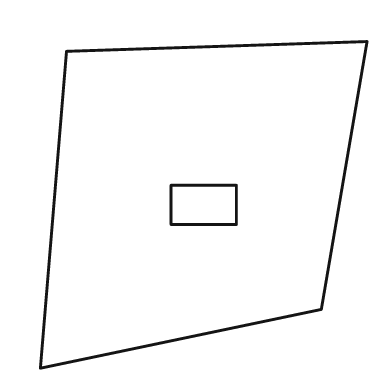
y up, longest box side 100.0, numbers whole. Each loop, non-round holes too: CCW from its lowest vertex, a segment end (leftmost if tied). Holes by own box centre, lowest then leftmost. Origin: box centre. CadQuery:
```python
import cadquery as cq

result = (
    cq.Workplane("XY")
    .moveTo(-50.0, -50.0)
    .lineTo(36.0, -32.0)
    .lineTo(50.0, 50.0)
    .lineTo(-42.0, 47.0)
    .close()
    .moveTo(-10.0, -6.0)
    .lineTo(10.0, -6.0)
    .lineTo(10.0, 6.0)
    .lineTo(-10.0, 6.0)
    .close()
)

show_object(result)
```